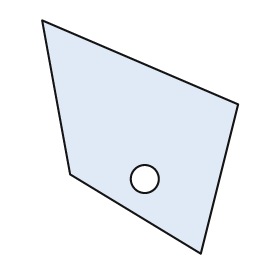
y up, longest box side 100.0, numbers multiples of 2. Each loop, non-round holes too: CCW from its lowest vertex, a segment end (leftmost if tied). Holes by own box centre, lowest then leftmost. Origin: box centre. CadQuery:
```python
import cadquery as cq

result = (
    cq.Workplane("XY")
    .moveTo(26.0, -50.0)
    .lineTo(42.0, 14.0)
    .lineTo(-42.0, 50.0)
    .lineTo(-30.0, -16.0)
    .close()
    .moveTo(2.0, -18.0)
    .circle(6.0)
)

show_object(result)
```